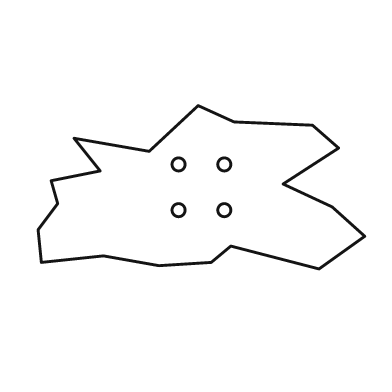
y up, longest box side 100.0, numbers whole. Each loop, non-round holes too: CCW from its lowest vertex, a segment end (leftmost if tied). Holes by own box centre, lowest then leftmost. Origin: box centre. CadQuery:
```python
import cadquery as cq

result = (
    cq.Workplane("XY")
    .moveTo(36.0, -25.0)
    .lineTo(50.0, -15.0)
    .lineTo(40.0, -6.0)
    .lineTo(25.0, 1.0)
    .lineTo(42.0, 12.0)
    .lineTo(34.0, 19.0)
    .lineTo(10.0, 20.0)
    .lineTo(-1.0, 25.0)
    .lineTo(-16.0, 11.0)
    .lineTo(-39.0, 15.0)
    .lineTo(-31.0, 5.0)
    .lineTo(-46.0, 2.0)
    .lineTo(-44.0, -5.0)
    .lineTo(-50.0, -13.0)
    .lineTo(-49.0, -23.0)
    .lineTo(-30.0, -21.0)
    .lineTo(-13.0, -24.0)
    .lineTo(3.0, -23.0)
    .lineTo(9.0, -18.0)
    .close()
    .moveTo(-7.0, -7.0)
    .circle(2.0)
    .moveTo(7.0, -7.0)
    .circle(2.0)
    .moveTo(-7.0, 7.0)
    .circle(2.0)
    .moveTo(7.0, 7.0)
    .circle(2.0)
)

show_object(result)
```